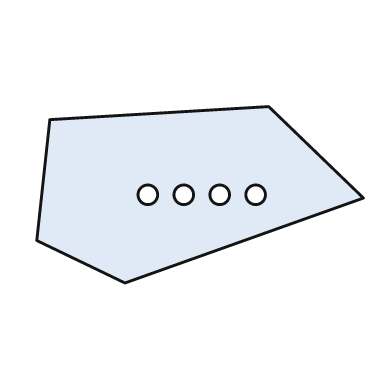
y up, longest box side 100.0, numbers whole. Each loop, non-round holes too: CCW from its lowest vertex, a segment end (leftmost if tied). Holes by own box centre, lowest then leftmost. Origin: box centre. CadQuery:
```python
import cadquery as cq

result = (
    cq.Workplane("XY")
    .moveTo(-23.0, -27.0)
    .lineTo(50.0, -1.0)
    .lineTo(21.0, 27.0)
    .lineTo(-46.0, 23.0)
    .lineTo(-50.0, -14.0)
    .close()
    .moveTo(-16.0, 0.0)
    .circle(3.0)
    .moveTo(-5.0, 0.0)
    .circle(3.0)
    .moveTo(6.0, 0.0)
    .circle(3.0)
    .moveTo(17.0, 0.0)
    .circle(3.0)
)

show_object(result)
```